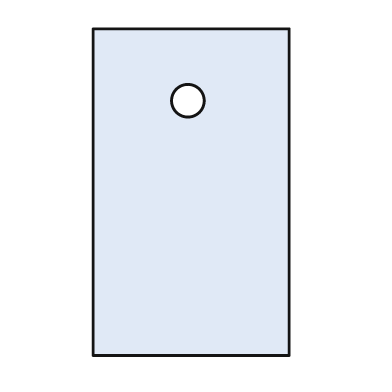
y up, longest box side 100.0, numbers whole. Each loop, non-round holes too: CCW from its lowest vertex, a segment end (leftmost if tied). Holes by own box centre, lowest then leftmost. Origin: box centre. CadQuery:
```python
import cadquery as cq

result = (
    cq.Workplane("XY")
    .moveTo(-30.0, -50.0)
    .lineTo(30.0, -50.0)
    .lineTo(30.0, 50.0)
    .lineTo(-30.0, 50.0)
    .close()
    .moveTo(-1.0, 28.0)
    .circle(5.0)
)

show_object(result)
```